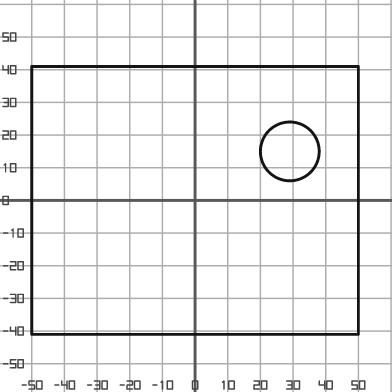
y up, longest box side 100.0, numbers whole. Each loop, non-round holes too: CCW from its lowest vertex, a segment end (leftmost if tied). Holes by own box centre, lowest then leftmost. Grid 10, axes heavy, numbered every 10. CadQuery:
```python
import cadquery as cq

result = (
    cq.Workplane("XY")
    .moveTo(-50.0, -41.0)
    .lineTo(50.0, -41.0)
    .lineTo(50.0, 41.0)
    .lineTo(-50.0, 41.0)
    .close()
    .moveTo(29.0, 15.0)
    .circle(9.0)
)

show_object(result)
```